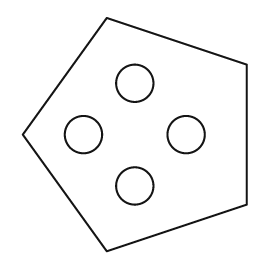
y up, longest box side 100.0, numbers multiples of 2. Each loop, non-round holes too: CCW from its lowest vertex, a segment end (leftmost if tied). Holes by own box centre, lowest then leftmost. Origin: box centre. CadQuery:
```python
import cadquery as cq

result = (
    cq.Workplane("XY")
    .moveTo(-12.0, -50.0)
    .lineTo(48.0, -30.0)
    .lineTo(48.0, 30.0)
    .lineTo(-12.0, 50.0)
    .lineTo(-48.0, 0.0)
    .close()
    .moveTo(0.0, -22.0)
    .circle(8.0)
    .moveTo(-22.0, 0.0)
    .circle(8.0)
    .moveTo(22.0, 0.0)
    .circle(8.0)
    .moveTo(0.0, 22.0)
    .circle(8.0)
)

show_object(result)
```